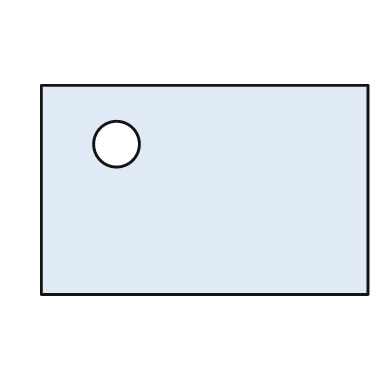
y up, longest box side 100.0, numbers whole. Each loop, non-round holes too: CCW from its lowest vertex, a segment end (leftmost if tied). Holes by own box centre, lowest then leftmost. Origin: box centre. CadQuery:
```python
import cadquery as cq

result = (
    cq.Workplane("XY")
    .moveTo(-50.0, -32.0)
    .lineTo(50.0, -32.0)
    .lineTo(50.0, 32.0)
    .lineTo(-50.0, 32.0)
    .close()
    .moveTo(-27.0, 14.0)
    .circle(7.0)
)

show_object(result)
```